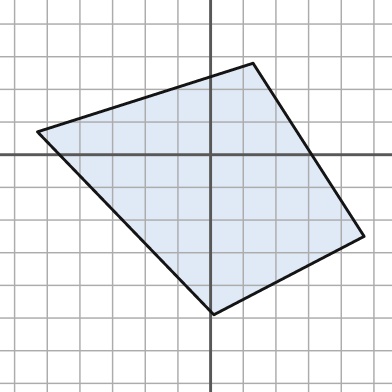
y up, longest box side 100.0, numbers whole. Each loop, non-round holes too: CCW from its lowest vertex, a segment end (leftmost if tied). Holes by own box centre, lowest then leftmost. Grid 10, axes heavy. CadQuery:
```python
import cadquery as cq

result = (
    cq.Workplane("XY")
    .moveTo(1.0, -49.0)
    .lineTo(47.0, -25.0)
    .lineTo(13.0, 28.0)
    .lineTo(-53.0, 7.0)
    .close()
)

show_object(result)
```